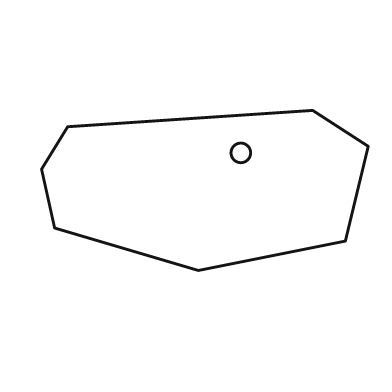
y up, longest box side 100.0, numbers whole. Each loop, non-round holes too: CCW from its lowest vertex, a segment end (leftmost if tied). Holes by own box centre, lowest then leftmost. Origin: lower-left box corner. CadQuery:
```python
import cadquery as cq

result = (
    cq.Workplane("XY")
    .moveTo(48.0, 0.0)
    .lineTo(93.0, 9.0)
    .lineTo(100.0, 38.0)
    .lineTo(83.0, 49.0)
    .lineTo(8.0, 44.0)
    .lineTo(0.0, 31.0)
    .lineTo(4.0, 13.0)
    .close()
    .moveTo(61.0, 36.0)
    .circle(3.0)
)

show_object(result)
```